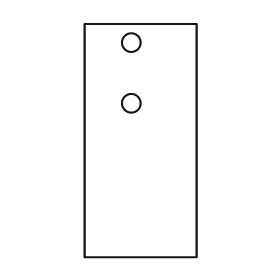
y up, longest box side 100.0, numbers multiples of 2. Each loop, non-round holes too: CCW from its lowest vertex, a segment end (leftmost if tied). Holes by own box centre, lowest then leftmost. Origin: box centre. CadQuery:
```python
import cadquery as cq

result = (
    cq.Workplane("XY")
    .moveTo(-24.0, -50.0)
    .lineTo(24.0, -50.0)
    .lineTo(24.0, 50.0)
    .lineTo(-24.0, 50.0)
    .close()
    .moveTo(-4.0, 16.0)
    .circle(4.0)
    .moveTo(-4.0, 42.0)
    .circle(4.0)
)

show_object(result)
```